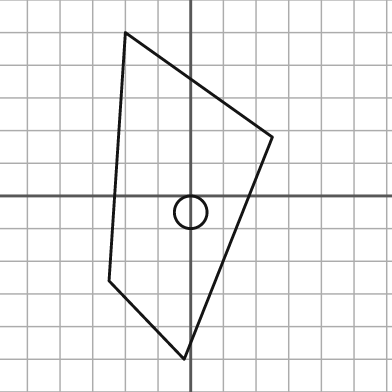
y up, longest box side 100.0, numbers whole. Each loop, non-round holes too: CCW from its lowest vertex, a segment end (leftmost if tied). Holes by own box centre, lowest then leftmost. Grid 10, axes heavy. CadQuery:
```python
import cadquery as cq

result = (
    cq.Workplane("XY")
    .moveTo(-2.0, -50.0)
    .lineTo(25.0, 18.0)
    .lineTo(-20.0, 50.0)
    .lineTo(-25.0, -26.0)
    .close()
    .moveTo(0.0, -5.0)
    .circle(5.0)
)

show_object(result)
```